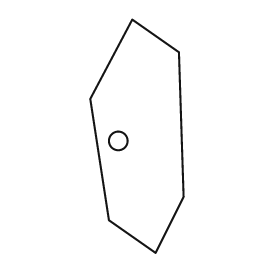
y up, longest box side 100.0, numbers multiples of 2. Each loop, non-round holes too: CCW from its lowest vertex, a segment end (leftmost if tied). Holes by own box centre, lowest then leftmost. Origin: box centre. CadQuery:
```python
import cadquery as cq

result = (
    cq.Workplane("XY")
    .moveTo(8.0, -50.0)
    .lineTo(20.0, -26.0)
    .lineTo(18.0, 36.0)
    .lineTo(-2.0, 50.0)
    .lineTo(-20.0, 16.0)
    .lineTo(-12.0, -36.0)
    .close()
    .moveTo(-8.0, -2.0)
    .circle(4.0)
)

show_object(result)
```